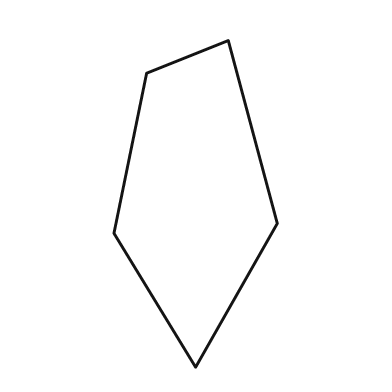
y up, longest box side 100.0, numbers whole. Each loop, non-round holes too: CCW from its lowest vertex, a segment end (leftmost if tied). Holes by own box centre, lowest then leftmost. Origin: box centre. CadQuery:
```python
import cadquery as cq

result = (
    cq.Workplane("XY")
    .moveTo(0.0, -50.0)
    .lineTo(25.0, -6.0)
    .lineTo(10.0, 50.0)
    .lineTo(-15.0, 40.0)
    .lineTo(-25.0, -9.0)
    .close()
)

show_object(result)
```